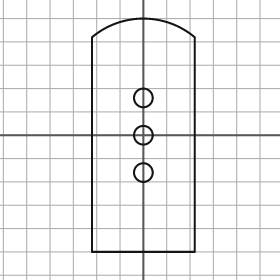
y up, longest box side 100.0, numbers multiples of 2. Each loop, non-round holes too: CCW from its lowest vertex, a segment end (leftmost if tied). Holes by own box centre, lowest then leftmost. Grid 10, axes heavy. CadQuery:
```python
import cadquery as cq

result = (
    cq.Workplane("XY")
    .moveTo(-22.0, -50.0)
    .lineTo(22.0, -50.0)
    .lineTo(22.0, 42.0)
    .threePointArc((0.0, 50.0), (-22.0, 42.0))
    .close()
    .moveTo(0.0, -16.0)
    .circle(4.0)
    .moveTo(0.0, 0.0)
    .circle(4.0)
    .moveTo(0.0, 16.0)
    .circle(4.0)
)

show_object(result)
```